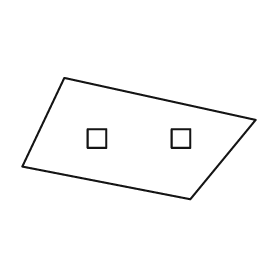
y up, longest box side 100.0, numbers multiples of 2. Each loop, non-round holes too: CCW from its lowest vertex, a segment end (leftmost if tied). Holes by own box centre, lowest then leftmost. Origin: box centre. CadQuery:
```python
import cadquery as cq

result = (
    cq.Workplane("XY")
    .moveTo(22.0, -26.0)
    .lineTo(50.0, 8.0)
    .lineTo(-32.0, 26.0)
    .lineTo(-50.0, -12.0)
    .close()
    .moveTo(-22.0, -4.0)
    .lineTo(-14.0, -4.0)
    .lineTo(-14.0, 4.0)
    .lineTo(-22.0, 4.0)
    .close()
    .moveTo(14.0, -4.0)
    .lineTo(22.0, -4.0)
    .lineTo(22.0, 4.0)
    .lineTo(14.0, 4.0)
    .close()
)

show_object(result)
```